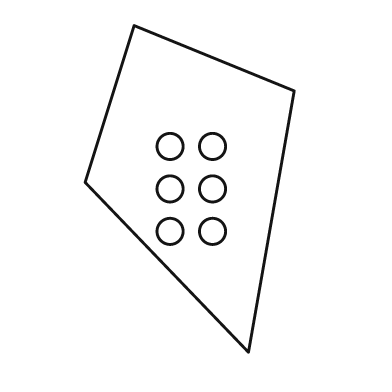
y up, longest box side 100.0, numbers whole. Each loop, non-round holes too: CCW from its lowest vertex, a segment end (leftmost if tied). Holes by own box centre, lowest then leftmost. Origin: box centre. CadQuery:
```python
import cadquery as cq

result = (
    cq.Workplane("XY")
    .moveTo(18.0, -50.0)
    .lineTo(32.0, 30.0)
    .lineTo(-17.0, 50.0)
    .lineTo(-32.0, 2.0)
    .close()
    .moveTo(-6.0, -13.0)
    .circle(4.0)
    .moveTo(7.0, -13.0)
    .circle(4.0)
    .moveTo(-6.0, 0.0)
    .circle(4.0)
    .moveTo(7.0, 0.0)
    .circle(4.0)
    .moveTo(-6.0, 13.0)
    .circle(4.0)
    .moveTo(7.0, 13.0)
    .circle(4.0)
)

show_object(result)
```